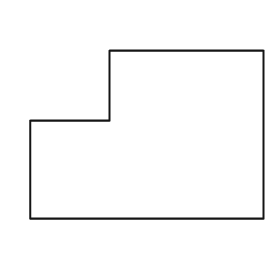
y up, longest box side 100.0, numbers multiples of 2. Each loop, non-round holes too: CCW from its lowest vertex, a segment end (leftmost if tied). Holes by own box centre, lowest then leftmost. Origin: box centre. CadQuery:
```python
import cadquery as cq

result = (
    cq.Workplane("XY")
    .moveTo(-50.0, -36.0)
    .lineTo(50.0, -36.0)
    .lineTo(50.0, 36.0)
    .lineTo(-16.0, 36.0)
    .lineTo(-16.0, 6.0)
    .lineTo(-50.0, 6.0)
    .close()
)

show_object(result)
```